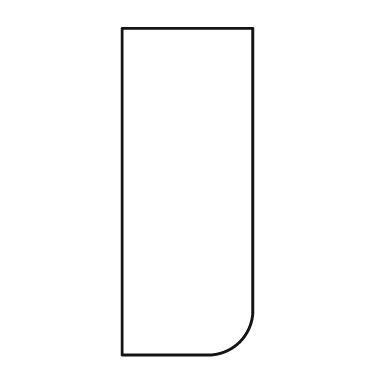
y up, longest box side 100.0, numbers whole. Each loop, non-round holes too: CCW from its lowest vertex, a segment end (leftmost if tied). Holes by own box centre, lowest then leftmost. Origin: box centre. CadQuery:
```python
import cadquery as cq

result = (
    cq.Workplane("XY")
    .moveTo(-20.0, -50.0)
    .lineTo(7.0, -50.0)
    .threePointArc((16.0, -46.0), (20.0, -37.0))
    .lineTo(20.0, 50.0)
    .lineTo(-20.0, 50.0)
    .close()
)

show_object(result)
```